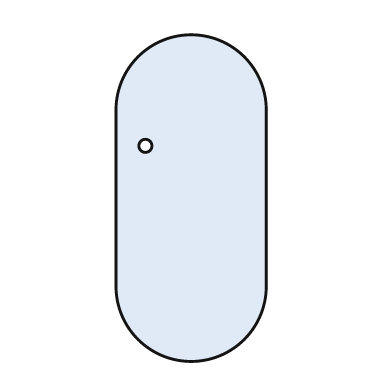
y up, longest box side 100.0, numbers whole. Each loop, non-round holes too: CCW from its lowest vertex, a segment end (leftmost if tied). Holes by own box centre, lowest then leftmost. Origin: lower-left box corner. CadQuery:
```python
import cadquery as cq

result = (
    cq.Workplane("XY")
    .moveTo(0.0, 23.0)
    .threePointArc((23.0, 0.0), (46.0, 23.0))
    .lineTo(46.0, 77.0)
    .threePointArc((23.0, 100.0), (0.0, 77.0))
    .close()
    .moveTo(9.0, 66.0)
    .circle(2.0)
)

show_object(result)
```